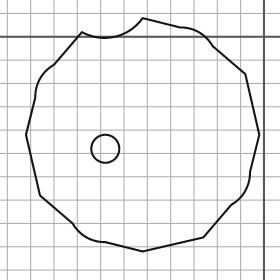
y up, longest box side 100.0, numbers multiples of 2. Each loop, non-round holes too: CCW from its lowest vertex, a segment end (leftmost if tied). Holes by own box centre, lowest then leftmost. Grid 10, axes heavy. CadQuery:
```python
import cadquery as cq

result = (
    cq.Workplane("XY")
    .moveTo(-52.0, -92.0)
    .lineTo(-26.0, -86.0)
    .lineTo(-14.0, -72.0)
    .threePointArc((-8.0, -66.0), (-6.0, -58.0))
    .lineTo(-2.0, -42.0)
    .lineTo(-8.0, -16.0)
    .lineTo(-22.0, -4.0)
    .threePointArc((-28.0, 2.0), (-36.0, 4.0))
    .lineTo(-52.0, 8.0)
    .threePointArc((-64.0, 0.0), (-78.0, 2.0))
    .lineTo(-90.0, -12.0)
    .threePointArc((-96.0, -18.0), (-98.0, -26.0))
    .lineTo(-102.0, -42.0)
    .lineTo(-96.0, -68.0)
    .lineTo(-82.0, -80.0)
    .threePointArc((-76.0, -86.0), (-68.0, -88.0))
    .close()
    .moveTo(-68.0, -48.0)
    .circle(6.0)
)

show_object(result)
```